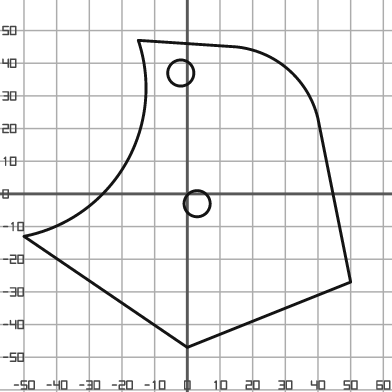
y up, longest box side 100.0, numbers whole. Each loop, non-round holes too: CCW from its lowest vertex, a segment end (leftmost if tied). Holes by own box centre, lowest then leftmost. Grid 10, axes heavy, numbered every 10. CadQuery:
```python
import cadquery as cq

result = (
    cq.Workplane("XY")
    .moveTo(0.0, -47.0)
    .lineTo(50.0, -27.0)
    .lineTo(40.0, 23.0)
    .threePointArc((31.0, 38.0), (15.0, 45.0))
    .lineTo(-15.0, 47.0)
    .threePointArc((-19.0, 9.0), (-50.0, -13.0))
    .close()
    .moveTo(3.0, -3.0)
    .circle(4.0)
    .moveTo(-2.0, 37.0)
    .circle(4.0)
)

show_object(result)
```